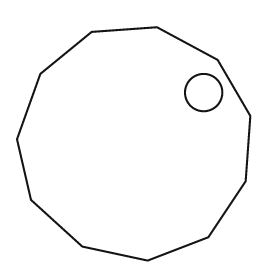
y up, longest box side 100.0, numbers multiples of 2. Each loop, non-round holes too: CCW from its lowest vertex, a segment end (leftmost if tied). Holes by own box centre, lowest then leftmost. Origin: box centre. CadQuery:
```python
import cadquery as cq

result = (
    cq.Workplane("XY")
    .moveTo(6.0, -50.0)
    .lineTo(32.0, -40.0)
    .lineTo(48.0, -16.0)
    .lineTo(50.0, 12.0)
    .lineTo(36.0, 36.0)
    .lineTo(10.0, 50.0)
    .lineTo(-18.0, 48.0)
    .lineTo(-40.0, 30.0)
    .lineTo(-50.0, 2.0)
    .lineTo(-44.0, -24.0)
    .lineTo(-22.0, -44.0)
    .close()
    .moveTo(30.0, 22.0)
    .circle(8.0)
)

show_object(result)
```